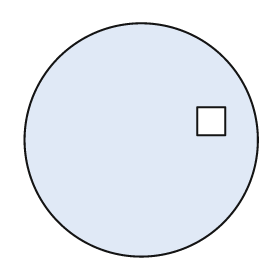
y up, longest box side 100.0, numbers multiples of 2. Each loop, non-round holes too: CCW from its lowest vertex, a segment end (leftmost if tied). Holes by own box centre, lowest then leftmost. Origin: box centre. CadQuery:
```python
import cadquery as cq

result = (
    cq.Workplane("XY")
    .moveTo(0.0, 0.0)
    .circle(50.0)
    .moveTo(24.0, 2.0)
    .lineTo(36.0, 2.0)
    .lineTo(36.0, 14.0)
    .lineTo(24.0, 14.0)
    .close()
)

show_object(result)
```